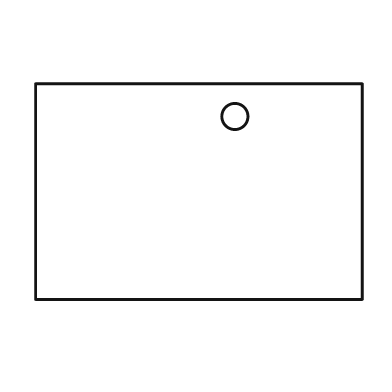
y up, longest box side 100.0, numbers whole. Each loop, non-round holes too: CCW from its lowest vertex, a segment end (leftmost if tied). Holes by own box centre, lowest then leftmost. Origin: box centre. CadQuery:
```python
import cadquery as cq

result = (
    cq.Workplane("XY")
    .moveTo(-50.0, -33.0)
    .lineTo(50.0, -33.0)
    .lineTo(50.0, 33.0)
    .lineTo(-50.0, 33.0)
    .close()
    .moveTo(11.0, 23.0)
    .circle(4.0)
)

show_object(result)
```